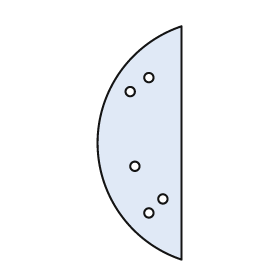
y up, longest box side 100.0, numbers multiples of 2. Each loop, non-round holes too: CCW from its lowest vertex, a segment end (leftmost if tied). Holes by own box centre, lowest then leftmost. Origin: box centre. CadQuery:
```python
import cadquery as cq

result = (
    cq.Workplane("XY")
    .moveTo(18.0, -50.0)
    .lineTo(18.0, 50.0)
    .threePointArc((-18.0, 0.0), (18.0, -50.0))
    .close()
    .moveTo(4.0, -30.0)
    .circle(2.0)
    .moveTo(10.0, -24.0)
    .circle(2.0)
    .moveTo(-2.0, -10.0)
    .circle(2.0)
    .moveTo(-4.0, 22.0)
    .circle(2.0)
    .moveTo(4.0, 28.0)
    .circle(2.0)
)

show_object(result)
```